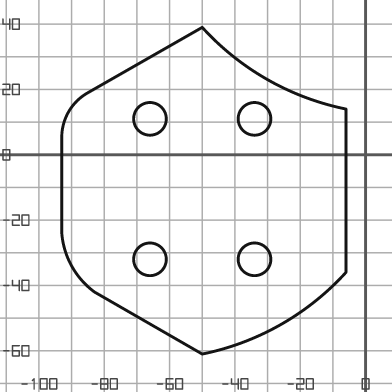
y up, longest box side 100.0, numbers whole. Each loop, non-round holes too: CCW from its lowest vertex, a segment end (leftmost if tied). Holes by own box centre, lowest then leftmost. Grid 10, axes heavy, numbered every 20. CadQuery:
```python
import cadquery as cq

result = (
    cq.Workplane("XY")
    .moveTo(-50.0, -61.0)
    .threePointArc((-26.0, -52.0), (-6.0, -36.0))
    .lineTo(-6.0, 14.0)
    .threePointArc((-30.0, 23.0), (-50.0, 39.0))
    .lineTo(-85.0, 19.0)
    .threePointArc((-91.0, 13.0), (-93.0, 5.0))
    .lineTo(-93.0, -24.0)
    .threePointArc((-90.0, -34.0), (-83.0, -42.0))
    .close()
    .moveTo(-66.0, -32.0)
    .circle(5.0)
    .moveTo(-34.0, -32.0)
    .circle(5.0)
    .moveTo(-66.0, 11.0)
    .circle(5.0)
    .moveTo(-34.0, 11.0)
    .circle(5.0)
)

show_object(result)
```